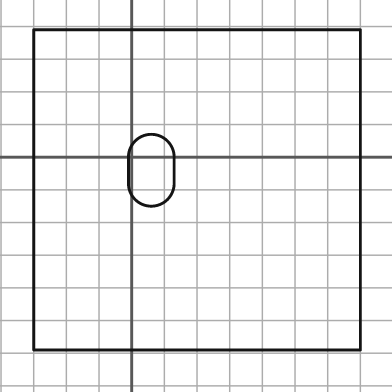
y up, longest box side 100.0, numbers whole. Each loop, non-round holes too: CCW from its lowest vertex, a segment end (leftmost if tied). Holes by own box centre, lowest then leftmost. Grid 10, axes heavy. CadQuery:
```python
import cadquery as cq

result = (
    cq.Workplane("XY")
    .moveTo(-30.0, -59.0)
    .lineTo(70.0, -59.0)
    .lineTo(70.0, 39.0)
    .lineTo(-30.0, 39.0)
    .close()
    .moveTo(-1.0, -8.0)
    .threePointArc((6.0, -15.0), (13.0, -8.0))
    .lineTo(13.0, 0.0)
    .threePointArc((6.0, 7.0), (-1.0, 0.0))
    .close()
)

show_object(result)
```